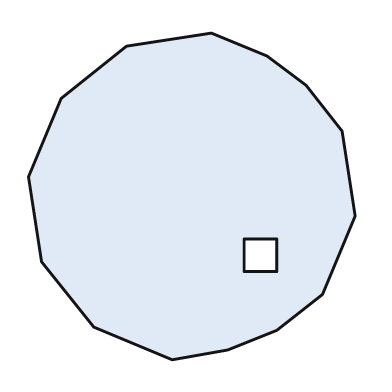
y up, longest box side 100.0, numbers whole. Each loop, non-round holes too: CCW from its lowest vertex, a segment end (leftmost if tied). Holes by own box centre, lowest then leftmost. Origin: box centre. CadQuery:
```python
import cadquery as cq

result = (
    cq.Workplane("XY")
    .moveTo(-6.0, -50.0)
    .lineTo(11.0, -47.0)
    .lineTo(26.0, -41.0)
    .lineTo(40.0, -30.0)
    .lineTo(50.0, -6.0)
    .lineTo(46.0, 20.0)
    .lineTo(35.0, 34.0)
    .lineTo(23.0, 43.0)
    .lineTo(6.0, 50.0)
    .lineTo(-20.0, 46.0)
    .lineTo(-40.0, 30.0)
    .lineTo(-50.0, 6.0)
    .lineTo(-46.0, -20.0)
    .lineTo(-30.0, -40.0)
    .close()
    .moveTo(16.0, -23.0)
    .lineTo(26.0, -23.0)
    .lineTo(26.0, -13.0)
    .lineTo(16.0, -13.0)
    .close()
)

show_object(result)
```